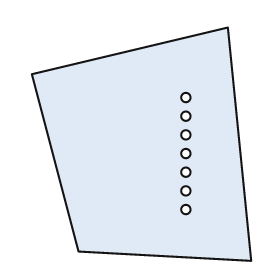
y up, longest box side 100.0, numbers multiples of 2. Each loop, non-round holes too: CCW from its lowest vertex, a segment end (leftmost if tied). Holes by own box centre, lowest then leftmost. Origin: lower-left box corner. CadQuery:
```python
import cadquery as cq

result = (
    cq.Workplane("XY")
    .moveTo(94.0, 0.0)
    .lineTo(84.0, 100.0)
    .lineTo(0.0, 80.0)
    .lineTo(20.0, 4.0)
    .close()
    .moveTo(66.0, 22.0)
    .circle(2.0)
    .moveTo(66.0, 30.0)
    .circle(2.0)
    .moveTo(66.0, 38.0)
    .circle(2.0)
    .moveTo(66.0, 46.0)
    .circle(2.0)
    .moveTo(66.0, 54.0)
    .circle(2.0)
    .moveTo(66.0, 62.0)
    .circle(2.0)
    .moveTo(66.0, 70.0)
    .circle(2.0)
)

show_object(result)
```